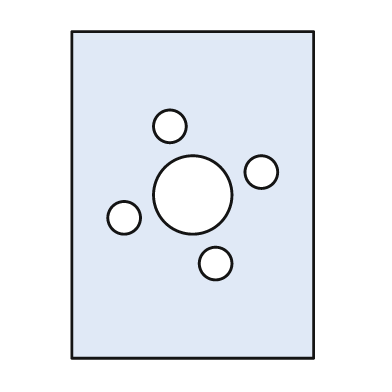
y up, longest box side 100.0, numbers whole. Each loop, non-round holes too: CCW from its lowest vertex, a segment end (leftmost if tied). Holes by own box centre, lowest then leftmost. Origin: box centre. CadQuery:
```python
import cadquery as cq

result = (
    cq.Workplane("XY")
    .moveTo(-37.0, -50.0)
    .lineTo(37.0, -50.0)
    .lineTo(37.0, 50.0)
    .lineTo(-37.0, 50.0)
    .close()
    .moveTo(7.0, -21.0)
    .circle(5.0)
    .moveTo(-21.0, -7.0)
    .circle(5.0)
    .moveTo(0.0, 0.0)
    .circle(12.0)
    .moveTo(21.0, 7.0)
    .circle(5.0)
    .moveTo(-7.0, 21.0)
    .circle(5.0)
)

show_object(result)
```